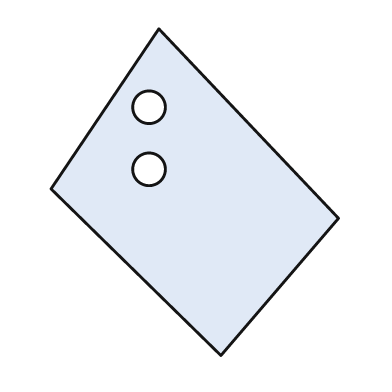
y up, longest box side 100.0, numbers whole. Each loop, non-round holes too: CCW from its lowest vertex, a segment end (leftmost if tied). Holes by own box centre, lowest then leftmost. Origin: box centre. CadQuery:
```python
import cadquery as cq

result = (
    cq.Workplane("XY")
    .moveTo(8.0, -50.0)
    .lineTo(44.0, -8.0)
    .lineTo(-11.0, 50.0)
    .lineTo(-44.0, 1.0)
    .close()
    .moveTo(-14.0, 7.0)
    .circle(5.0)
    .moveTo(-14.0, 26.0)
    .circle(5.0)
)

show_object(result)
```